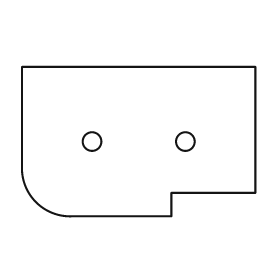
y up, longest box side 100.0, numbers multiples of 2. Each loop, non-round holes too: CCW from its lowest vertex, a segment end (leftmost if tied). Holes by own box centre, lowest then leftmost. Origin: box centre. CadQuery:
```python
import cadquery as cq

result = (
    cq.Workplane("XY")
    .moveTo(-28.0, -32.0)
    .lineTo(14.0, -32.0)
    .lineTo(14.0, -22.0)
    .lineTo(50.0, -22.0)
    .lineTo(50.0, 32.0)
    .lineTo(-50.0, 32.0)
    .lineTo(-50.0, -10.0)
    .threePointArc((-44.0, -26.0), (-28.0, -32.0))
    .close()
    .moveTo(-20.0, 0.0)
    .circle(4.0)
    .moveTo(20.0, 0.0)
    .circle(4.0)
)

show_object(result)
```